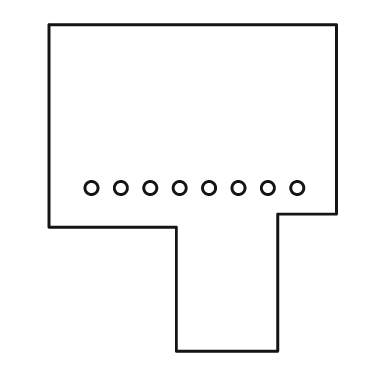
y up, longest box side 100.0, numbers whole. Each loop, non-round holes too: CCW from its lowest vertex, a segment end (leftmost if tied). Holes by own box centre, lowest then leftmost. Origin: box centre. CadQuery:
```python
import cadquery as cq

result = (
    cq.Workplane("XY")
    .moveTo(-5.0, -50.0)
    .lineTo(26.0, -50.0)
    .lineTo(26.0, -8.0)
    .lineTo(44.0, -8.0)
    .lineTo(44.0, 50.0)
    .lineTo(-44.0, 50.0)
    .lineTo(-44.0, -12.0)
    .lineTo(-5.0, -12.0)
    .close()
    .moveTo(-31.0, 0.0)
    .circle(2.0)
    .moveTo(-22.0, 0.0)
    .circle(2.0)
    .moveTo(-13.0, 0.0)
    .circle(2.0)
    .moveTo(-4.0, 0.0)
    .circle(2.0)
    .moveTo(5.0, 0.0)
    .circle(2.0)
    .moveTo(14.0, 0.0)
    .circle(2.0)
    .moveTo(23.0, 0.0)
    .circle(2.0)
    .moveTo(32.0, 0.0)
    .circle(2.0)
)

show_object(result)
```